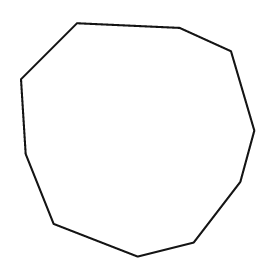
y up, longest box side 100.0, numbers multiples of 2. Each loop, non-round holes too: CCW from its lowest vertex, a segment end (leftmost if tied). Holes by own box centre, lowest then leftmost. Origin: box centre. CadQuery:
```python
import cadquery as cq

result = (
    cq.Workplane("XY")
    .moveTo(0.0, -50.0)
    .lineTo(24.0, -44.0)
    .lineTo(44.0, -18.0)
    .lineTo(50.0, 4.0)
    .lineTo(40.0, 38.0)
    .lineTo(18.0, 48.0)
    .lineTo(-26.0, 50.0)
    .lineTo(-50.0, 26.0)
    .lineTo(-48.0, -6.0)
    .lineTo(-36.0, -36.0)
    .close()
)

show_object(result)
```